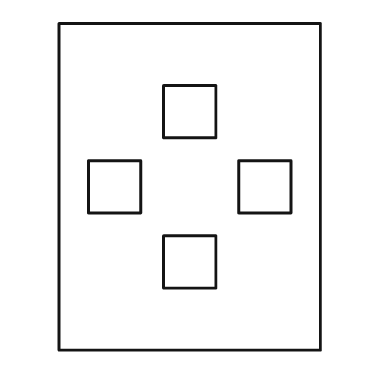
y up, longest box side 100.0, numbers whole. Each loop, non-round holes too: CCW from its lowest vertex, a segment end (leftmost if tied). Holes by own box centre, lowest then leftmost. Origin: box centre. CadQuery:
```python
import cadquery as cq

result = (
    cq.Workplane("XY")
    .moveTo(-40.0, -50.0)
    .lineTo(40.0, -50.0)
    .lineTo(40.0, 50.0)
    .lineTo(-40.0, 50.0)
    .close()
    .moveTo(-8.0, -31.0)
    .lineTo(8.0, -31.0)
    .lineTo(8.0, -15.0)
    .lineTo(-8.0, -15.0)
    .close()
    .moveTo(-31.0, -8.0)
    .lineTo(-15.0, -8.0)
    .lineTo(-15.0, 8.0)
    .lineTo(-31.0, 8.0)
    .close()
    .moveTo(15.0, -8.0)
    .lineTo(31.0, -8.0)
    .lineTo(31.0, 8.0)
    .lineTo(15.0, 8.0)
    .close()
    .moveTo(-8.0, 15.0)
    .lineTo(8.0, 15.0)
    .lineTo(8.0, 31.0)
    .lineTo(-8.0, 31.0)
    .close()
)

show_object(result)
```